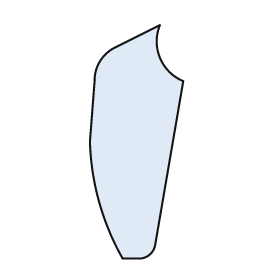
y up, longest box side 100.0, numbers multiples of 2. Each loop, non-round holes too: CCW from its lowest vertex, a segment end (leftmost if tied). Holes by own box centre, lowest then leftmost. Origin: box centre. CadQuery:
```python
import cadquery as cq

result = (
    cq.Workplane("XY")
    .moveTo(-6.0, -50.0)
    .lineTo(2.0, -50.0)
    .threePointArc((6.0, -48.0), (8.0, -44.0))
    .lineTo(20.0, 26.0)
    .threePointArc((10.0, 36.0), (10.0, 50.0))
    .lineTo(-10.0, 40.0)
    .threePointArc((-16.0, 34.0), (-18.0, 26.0))
    .lineTo(-20.0, 0.0)
    .threePointArc((-16.0, -26.0), (-6.0, -50.0))
    .close()
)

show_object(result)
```